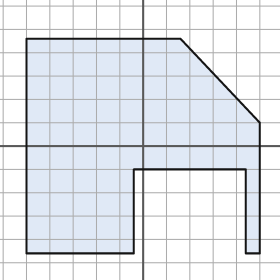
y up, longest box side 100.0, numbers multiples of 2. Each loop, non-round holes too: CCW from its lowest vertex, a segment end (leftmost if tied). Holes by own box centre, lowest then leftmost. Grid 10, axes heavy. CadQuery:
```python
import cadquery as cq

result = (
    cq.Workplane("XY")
    .moveTo(-50.0, -46.0)
    .lineTo(-4.0, -46.0)
    .lineTo(-4.0, -10.0)
    .lineTo(44.0, -10.0)
    .lineTo(44.0, -46.0)
    .lineTo(50.0, -46.0)
    .lineTo(50.0, 10.0)
    .lineTo(16.0, 46.0)
    .lineTo(-50.0, 46.0)
    .close()
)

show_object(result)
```